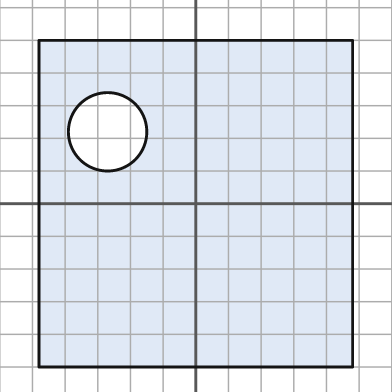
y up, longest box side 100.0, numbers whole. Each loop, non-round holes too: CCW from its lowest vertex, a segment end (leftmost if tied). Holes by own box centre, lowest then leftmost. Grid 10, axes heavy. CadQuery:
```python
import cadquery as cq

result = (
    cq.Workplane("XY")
    .moveTo(-48.0, -50.0)
    .lineTo(48.0, -50.0)
    .lineTo(48.0, 50.0)
    .lineTo(-48.0, 50.0)
    .close()
    .moveTo(-27.0, 22.0)
    .circle(12.0)
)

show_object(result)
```